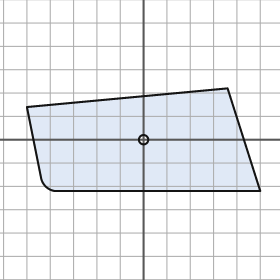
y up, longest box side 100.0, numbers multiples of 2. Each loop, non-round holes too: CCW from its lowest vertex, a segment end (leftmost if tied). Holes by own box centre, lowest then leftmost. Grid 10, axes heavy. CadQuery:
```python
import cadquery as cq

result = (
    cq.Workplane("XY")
    .moveTo(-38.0, -22.0)
    .lineTo(50.0, -22.0)
    .lineTo(36.0, 22.0)
    .lineTo(-50.0, 14.0)
    .lineTo(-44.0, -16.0)
    .threePointArc((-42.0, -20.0), (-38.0, -22.0))
    .close()
    .moveTo(0.0, 0.0)
    .circle(2.0)
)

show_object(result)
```